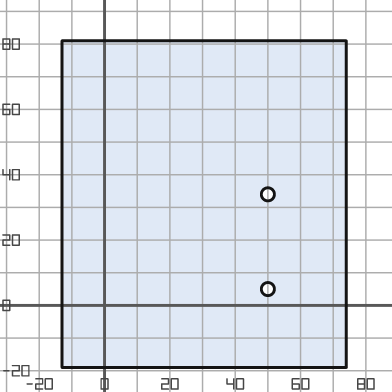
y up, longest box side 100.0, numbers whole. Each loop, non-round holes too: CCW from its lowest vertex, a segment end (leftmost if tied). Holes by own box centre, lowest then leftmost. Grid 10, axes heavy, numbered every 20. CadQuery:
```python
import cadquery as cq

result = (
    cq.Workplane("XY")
    .moveTo(-13.0, -19.0)
    .lineTo(74.0, -19.0)
    .lineTo(74.0, 81.0)
    .lineTo(-13.0, 81.0)
    .close()
    .moveTo(50.0, 5.0)
    .circle(2.0)
    .moveTo(50.0, 34.0)
    .circle(2.0)
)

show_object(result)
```